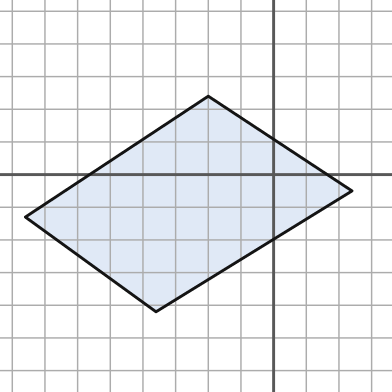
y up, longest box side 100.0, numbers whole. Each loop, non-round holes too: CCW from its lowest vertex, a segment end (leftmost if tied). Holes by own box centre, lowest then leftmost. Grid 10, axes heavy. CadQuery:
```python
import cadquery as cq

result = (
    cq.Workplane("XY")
    .moveTo(-36.0, -42.0)
    .lineTo(24.0, -5.0)
    .lineTo(-20.0, 24.0)
    .lineTo(-76.0, -13.0)
    .close()
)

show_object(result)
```